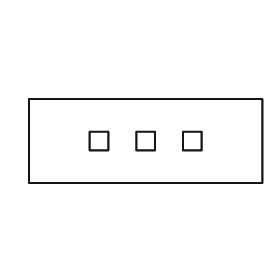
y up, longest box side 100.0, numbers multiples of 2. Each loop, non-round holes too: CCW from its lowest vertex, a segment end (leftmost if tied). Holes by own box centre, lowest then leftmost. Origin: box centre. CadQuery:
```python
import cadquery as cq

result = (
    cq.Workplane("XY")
    .moveTo(-50.0, -18.0)
    .lineTo(50.0, -18.0)
    .lineTo(50.0, 18.0)
    .lineTo(-50.0, 18.0)
    .close()
    .moveTo(-24.0, -4.0)
    .lineTo(-16.0, -4.0)
    .lineTo(-16.0, 4.0)
    .lineTo(-24.0, 4.0)
    .close()
    .moveTo(-4.0, -4.0)
    .lineTo(4.0, -4.0)
    .lineTo(4.0, 4.0)
    .lineTo(-4.0, 4.0)
    .close()
    .moveTo(16.0, -4.0)
    .lineTo(24.0, -4.0)
    .lineTo(24.0, 4.0)
    .lineTo(16.0, 4.0)
    .close()
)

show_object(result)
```